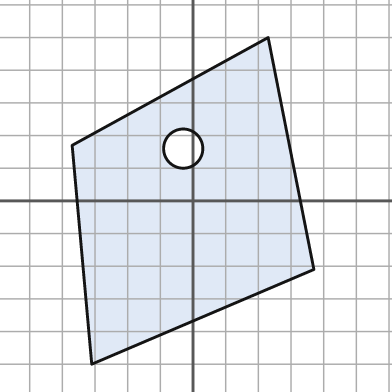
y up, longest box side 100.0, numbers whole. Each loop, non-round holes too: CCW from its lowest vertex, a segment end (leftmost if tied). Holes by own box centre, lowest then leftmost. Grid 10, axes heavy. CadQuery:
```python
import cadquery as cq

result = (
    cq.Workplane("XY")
    .moveTo(-31.0, -50.0)
    .lineTo(37.0, -21.0)
    .lineTo(23.0, 50.0)
    .lineTo(-37.0, 17.0)
    .close()
    .moveTo(-3.0, 16.0)
    .circle(6.0)
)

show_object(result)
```